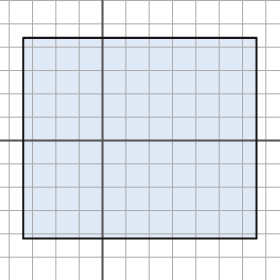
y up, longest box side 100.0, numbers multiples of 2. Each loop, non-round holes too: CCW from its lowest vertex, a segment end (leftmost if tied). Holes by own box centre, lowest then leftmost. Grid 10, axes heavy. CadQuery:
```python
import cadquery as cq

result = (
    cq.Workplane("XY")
    .moveTo(-34.0, -42.0)
    .lineTo(66.0, -42.0)
    .lineTo(66.0, 44.0)
    .lineTo(-34.0, 44.0)
    .close()
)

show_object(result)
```